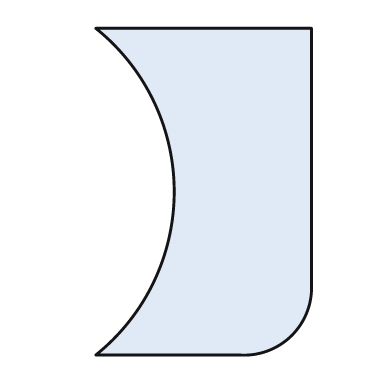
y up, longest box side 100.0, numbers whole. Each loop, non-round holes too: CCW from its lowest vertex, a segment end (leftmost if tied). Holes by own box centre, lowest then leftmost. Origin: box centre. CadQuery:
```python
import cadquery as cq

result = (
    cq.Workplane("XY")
    .moveTo(-33.0, -50.0)
    .lineTo(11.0, -50.0)
    .threePointArc((27.0, -44.0), (33.0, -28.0))
    .lineTo(33.0, 50.0)
    .lineTo(-33.0, 50.0)
    .threePointArc((-9.0, 0.0), (-33.0, -50.0))
    .close()
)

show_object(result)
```